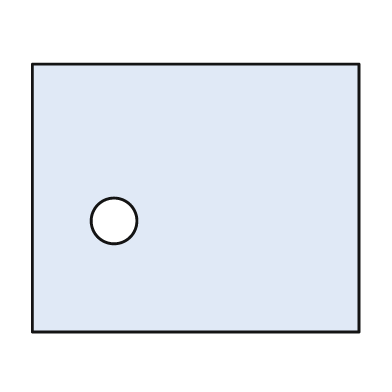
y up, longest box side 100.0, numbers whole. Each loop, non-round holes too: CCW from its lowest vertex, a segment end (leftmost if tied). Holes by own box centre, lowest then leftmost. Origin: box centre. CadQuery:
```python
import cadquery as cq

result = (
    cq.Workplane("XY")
    .moveTo(-50.0, -41.0)
    .lineTo(50.0, -41.0)
    .lineTo(50.0, 41.0)
    .lineTo(-50.0, 41.0)
    .close()
    .moveTo(-25.0, -7.0)
    .circle(7.0)
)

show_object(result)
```